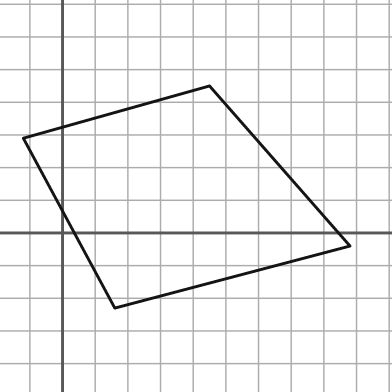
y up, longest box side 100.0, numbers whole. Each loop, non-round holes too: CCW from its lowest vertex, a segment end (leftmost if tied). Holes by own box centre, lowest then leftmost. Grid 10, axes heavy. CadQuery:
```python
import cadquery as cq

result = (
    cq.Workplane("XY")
    .moveTo(16.0, -23.0)
    .lineTo(88.0, -4.0)
    .lineTo(45.0, 45.0)
    .lineTo(-12.0, 29.0)
    .close()
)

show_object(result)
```